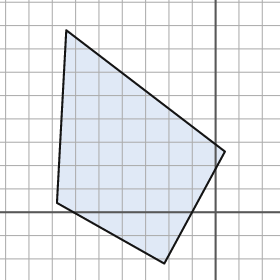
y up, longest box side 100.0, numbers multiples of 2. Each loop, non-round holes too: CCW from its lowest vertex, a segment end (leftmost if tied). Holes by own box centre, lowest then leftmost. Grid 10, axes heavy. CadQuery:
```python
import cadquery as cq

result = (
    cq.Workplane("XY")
    .moveTo(-22.0, -22.0)
    .lineTo(4.0, 26.0)
    .lineTo(-64.0, 78.0)
    .lineTo(-68.0, 4.0)
    .close()
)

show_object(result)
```